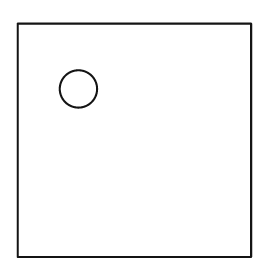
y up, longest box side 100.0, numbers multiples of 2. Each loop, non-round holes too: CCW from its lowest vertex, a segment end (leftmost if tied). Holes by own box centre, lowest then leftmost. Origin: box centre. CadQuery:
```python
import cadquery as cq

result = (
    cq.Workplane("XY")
    .moveTo(-50.0, -50.0)
    .lineTo(50.0, -50.0)
    .lineTo(50.0, 50.0)
    .lineTo(-50.0, 50.0)
    .close()
    .moveTo(-24.0, 22.0)
    .circle(8.0)
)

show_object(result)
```